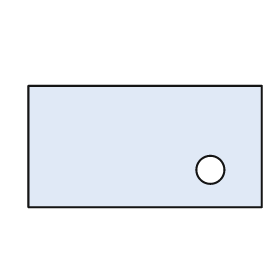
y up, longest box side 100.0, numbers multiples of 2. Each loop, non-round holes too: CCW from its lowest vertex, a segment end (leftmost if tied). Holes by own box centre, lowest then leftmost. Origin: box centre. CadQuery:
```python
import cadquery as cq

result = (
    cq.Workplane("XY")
    .moveTo(-50.0, -26.0)
    .lineTo(50.0, -26.0)
    .lineTo(50.0, 26.0)
    .lineTo(-50.0, 26.0)
    .close()
    .moveTo(28.0, -10.0)
    .circle(6.0)
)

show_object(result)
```